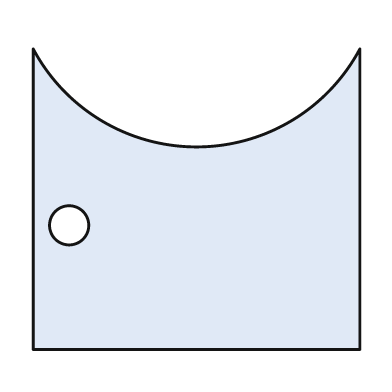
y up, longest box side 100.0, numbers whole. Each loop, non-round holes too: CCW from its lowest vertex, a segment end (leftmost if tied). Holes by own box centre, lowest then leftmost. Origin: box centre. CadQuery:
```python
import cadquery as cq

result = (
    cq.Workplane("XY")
    .moveTo(-50.0, -46.0)
    .lineTo(50.0, -46.0)
    .lineTo(50.0, 46.0)
    .threePointArc((0.0, 16.0), (-50.0, 46.0))
    .close()
    .moveTo(-39.0, -8.0)
    .circle(6.0)
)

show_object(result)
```